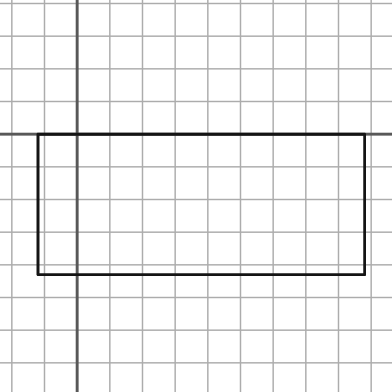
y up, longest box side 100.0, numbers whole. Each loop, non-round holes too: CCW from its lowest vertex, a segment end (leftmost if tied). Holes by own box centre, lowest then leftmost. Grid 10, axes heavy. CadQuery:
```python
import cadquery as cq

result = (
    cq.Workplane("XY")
    .moveTo(-12.0, -43.0)
    .lineTo(88.0, -43.0)
    .lineTo(88.0, 0.0)
    .lineTo(-12.0, 0.0)
    .close()
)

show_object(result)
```